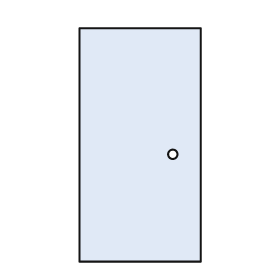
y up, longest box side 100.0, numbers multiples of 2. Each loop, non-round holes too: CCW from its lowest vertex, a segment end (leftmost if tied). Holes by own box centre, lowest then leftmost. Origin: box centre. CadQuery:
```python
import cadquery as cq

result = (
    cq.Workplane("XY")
    .moveTo(-26.0, -50.0)
    .lineTo(26.0, -50.0)
    .lineTo(26.0, 50.0)
    .lineTo(-26.0, 50.0)
    .close()
    .moveTo(14.0, -4.0)
    .circle(2.0)
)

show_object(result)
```